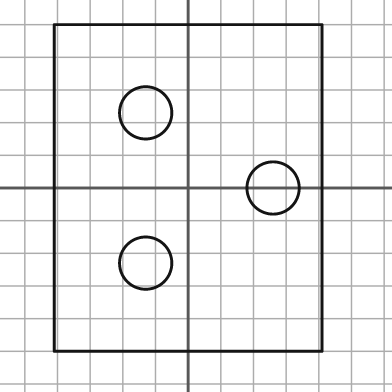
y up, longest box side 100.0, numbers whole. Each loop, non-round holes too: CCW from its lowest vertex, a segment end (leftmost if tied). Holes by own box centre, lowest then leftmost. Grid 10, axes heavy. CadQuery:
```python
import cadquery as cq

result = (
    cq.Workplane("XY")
    .moveTo(-41.0, -50.0)
    .lineTo(41.0, -50.0)
    .lineTo(41.0, 50.0)
    .lineTo(-41.0, 50.0)
    .close()
    .moveTo(-13.0, -23.0)
    .circle(8.0)
    .moveTo(26.0, 0.0)
    .circle(8.0)
    .moveTo(-13.0, 23.0)
    .circle(8.0)
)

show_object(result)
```